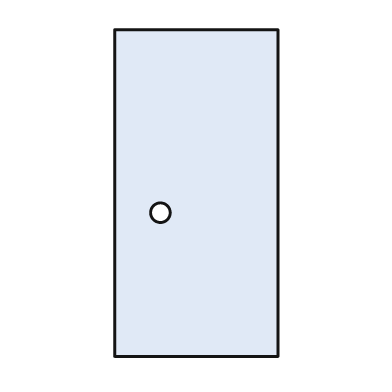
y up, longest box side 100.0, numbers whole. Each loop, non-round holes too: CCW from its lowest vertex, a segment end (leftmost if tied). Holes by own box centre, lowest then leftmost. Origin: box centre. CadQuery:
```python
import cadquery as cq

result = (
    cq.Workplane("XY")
    .moveTo(-25.0, -50.0)
    .lineTo(25.0, -50.0)
    .lineTo(25.0, 50.0)
    .lineTo(-25.0, 50.0)
    .close()
    .moveTo(-11.0, -6.0)
    .circle(3.0)
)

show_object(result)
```